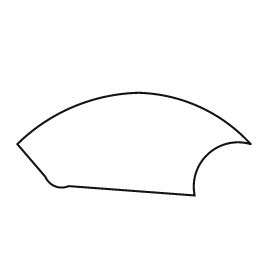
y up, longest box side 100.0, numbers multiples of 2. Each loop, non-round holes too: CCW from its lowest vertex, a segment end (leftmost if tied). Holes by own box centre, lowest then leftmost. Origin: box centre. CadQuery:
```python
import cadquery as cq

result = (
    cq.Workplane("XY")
    .moveTo(26.0, -22.0)
    .threePointArc((32.0, -4.0), (50.0, 0.0))
    .threePointArc((28.0, 16.0), (2.0, 22.0))
    .threePointArc((-26.0, 16.0), (-50.0, 0.0))
    .lineTo(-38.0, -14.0)
    .threePointArc((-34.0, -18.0), (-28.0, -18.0))
    .close()
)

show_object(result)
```